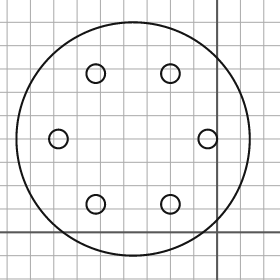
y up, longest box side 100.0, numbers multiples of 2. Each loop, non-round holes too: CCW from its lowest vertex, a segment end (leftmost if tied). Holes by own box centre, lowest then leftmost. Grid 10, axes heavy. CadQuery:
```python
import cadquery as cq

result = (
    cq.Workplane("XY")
    .moveTo(-36.0, 40.0)
    .circle(50.0)
    .moveTo(-52.0, 12.0)
    .circle(4.0)
    .moveTo(-20.0, 12.0)
    .circle(4.0)
    .moveTo(-68.0, 40.0)
    .circle(4.0)
    .moveTo(-4.0, 40.0)
    .circle(4.0)
    .moveTo(-52.0, 68.0)
    .circle(4.0)
    .moveTo(-20.0, 68.0)
    .circle(4.0)
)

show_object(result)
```